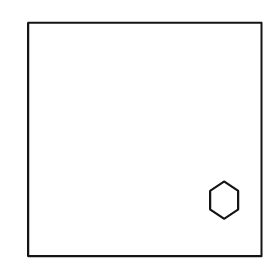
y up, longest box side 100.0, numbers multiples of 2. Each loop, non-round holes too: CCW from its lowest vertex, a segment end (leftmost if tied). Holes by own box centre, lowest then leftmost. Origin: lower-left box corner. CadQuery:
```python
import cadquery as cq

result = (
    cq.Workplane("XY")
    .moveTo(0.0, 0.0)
    .lineTo(100.0, 0.0)
    .lineTo(100.0, 100.0)
    .lineTo(0.0, 100.0)
    .close()
    .moveTo(84.0, 16.0)
    .lineTo(90.0, 20.0)
    .lineTo(90.0, 28.0)
    .lineTo(84.0, 32.0)
    .lineTo(78.0, 28.0)
    .lineTo(78.0, 20.0)
    .close()
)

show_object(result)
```